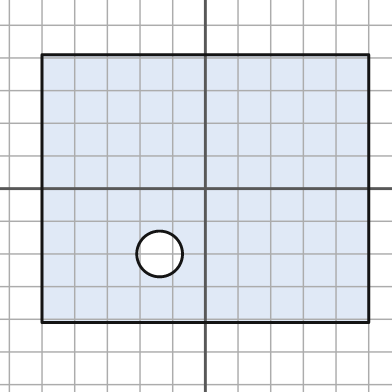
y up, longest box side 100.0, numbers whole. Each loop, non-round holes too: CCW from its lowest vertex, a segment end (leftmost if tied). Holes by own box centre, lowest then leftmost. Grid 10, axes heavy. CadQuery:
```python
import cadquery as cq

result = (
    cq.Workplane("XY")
    .moveTo(-50.0, -41.0)
    .lineTo(50.0, -41.0)
    .lineTo(50.0, 41.0)
    .lineTo(-50.0, 41.0)
    .close()
    .moveTo(-14.0, -20.0)
    .circle(7.0)
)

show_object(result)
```